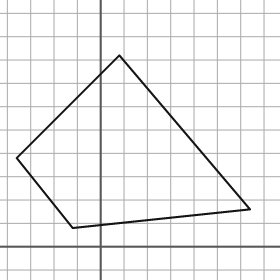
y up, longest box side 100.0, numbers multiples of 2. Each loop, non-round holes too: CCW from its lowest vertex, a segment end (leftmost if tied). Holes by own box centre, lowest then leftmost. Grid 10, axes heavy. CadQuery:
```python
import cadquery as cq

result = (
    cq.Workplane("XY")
    .moveTo(-12.0, 8.0)
    .lineTo(64.0, 16.0)
    .lineTo(8.0, 82.0)
    .lineTo(-36.0, 38.0)
    .close()
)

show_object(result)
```